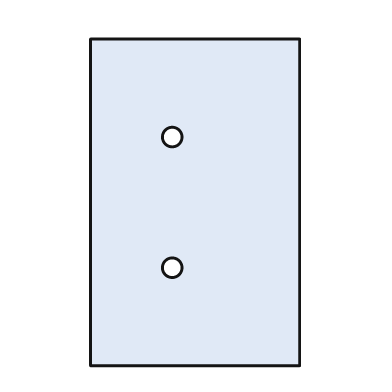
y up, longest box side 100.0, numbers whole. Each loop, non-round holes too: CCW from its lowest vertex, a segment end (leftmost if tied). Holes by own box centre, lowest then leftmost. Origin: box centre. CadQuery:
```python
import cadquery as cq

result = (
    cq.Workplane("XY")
    .moveTo(-32.0, -50.0)
    .lineTo(32.0, -50.0)
    .lineTo(32.0, 50.0)
    .lineTo(-32.0, 50.0)
    .close()
    .moveTo(-7.0, -20.0)
    .circle(3.0)
    .moveTo(-7.0, 20.0)
    .circle(3.0)
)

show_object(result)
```